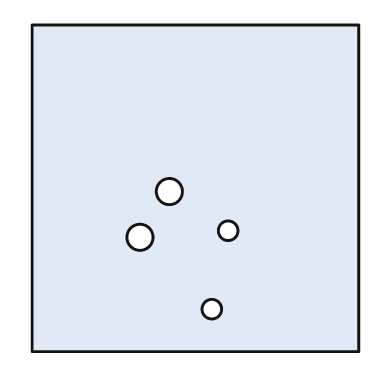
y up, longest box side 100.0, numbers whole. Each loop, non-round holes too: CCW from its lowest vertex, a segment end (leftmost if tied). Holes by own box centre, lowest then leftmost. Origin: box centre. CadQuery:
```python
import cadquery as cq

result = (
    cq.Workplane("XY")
    .moveTo(-50.0, -50.0)
    .lineTo(50.0, -50.0)
    .lineTo(50.0, 50.0)
    .lineTo(-50.0, 50.0)
    .close()
    .moveTo(5.0, -37.0)
    .circle(3.0)
    .moveTo(-17.0, -15.0)
    .circle(4.0)
    .moveTo(10.0, -13.0)
    .circle(3.0)
    .moveTo(-8.0, -1.0)
    .circle(4.0)
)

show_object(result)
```